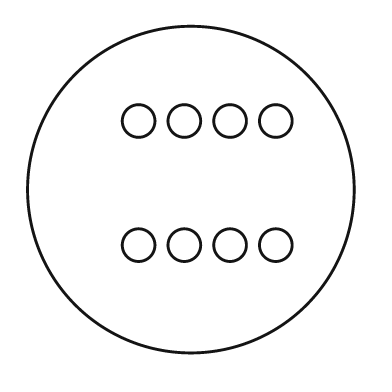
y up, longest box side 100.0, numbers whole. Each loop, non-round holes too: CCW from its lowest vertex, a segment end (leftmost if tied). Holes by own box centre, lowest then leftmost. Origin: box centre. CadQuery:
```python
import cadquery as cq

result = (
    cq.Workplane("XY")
    .moveTo(0.0, 0.0)
    .circle(50.0)
    .moveTo(-16.0, -17.0)
    .circle(5.0)
    .moveTo(-2.0, -17.0)
    .circle(5.0)
    .moveTo(12.0, -17.0)
    .circle(5.0)
    .moveTo(26.0, -17.0)
    .circle(5.0)
    .moveTo(-16.0, 21.0)
    .circle(5.0)
    .moveTo(-2.0, 21.0)
    .circle(5.0)
    .moveTo(12.0, 21.0)
    .circle(5.0)
    .moveTo(26.0, 21.0)
    .circle(5.0)
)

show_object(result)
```